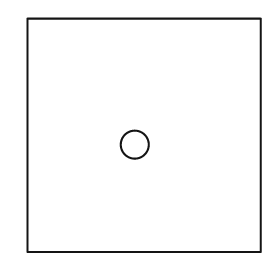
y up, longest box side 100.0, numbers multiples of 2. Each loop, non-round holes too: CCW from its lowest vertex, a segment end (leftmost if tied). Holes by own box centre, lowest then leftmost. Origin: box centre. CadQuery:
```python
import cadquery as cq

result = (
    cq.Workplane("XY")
    .moveTo(-50.0, -50.0)
    .lineTo(50.0, -50.0)
    .lineTo(50.0, 50.0)
    .lineTo(-50.0, 50.0)
    .close()
    .moveTo(-4.0, -4.0)
    .circle(6.0)
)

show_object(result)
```